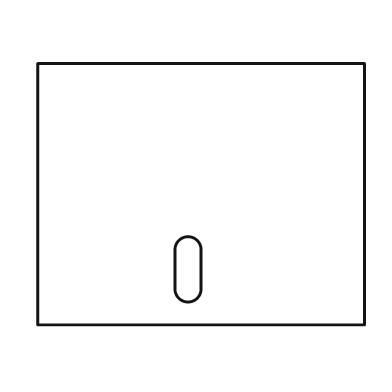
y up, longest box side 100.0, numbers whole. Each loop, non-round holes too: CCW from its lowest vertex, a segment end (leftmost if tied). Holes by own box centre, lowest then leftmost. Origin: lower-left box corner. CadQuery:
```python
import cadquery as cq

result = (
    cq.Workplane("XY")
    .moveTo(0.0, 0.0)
    .lineTo(100.0, 0.0)
    .lineTo(100.0, 80.0)
    .lineTo(0.0, 80.0)
    .close()
    .moveTo(42.0, 11.0)
    .threePointArc((46.0, 7.0), (50.0, 11.0))
    .lineTo(50.0, 23.0)
    .threePointArc((46.0, 27.0), (42.0, 23.0))
    .close()
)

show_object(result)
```